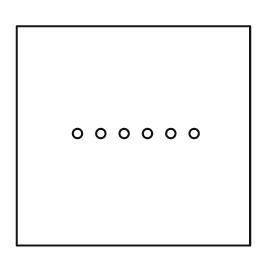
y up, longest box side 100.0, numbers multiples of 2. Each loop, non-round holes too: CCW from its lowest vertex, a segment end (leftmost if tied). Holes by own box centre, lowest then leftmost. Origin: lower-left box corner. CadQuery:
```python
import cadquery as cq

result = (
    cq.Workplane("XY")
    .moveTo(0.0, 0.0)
    .lineTo(100.0, 0.0)
    .lineTo(100.0, 94.0)
    .lineTo(0.0, 94.0)
    .close()
    .moveTo(26.0, 48.0)
    .circle(2.0)
    .moveTo(36.0, 48.0)
    .circle(2.0)
    .moveTo(46.0, 48.0)
    .circle(2.0)
    .moveTo(56.0, 48.0)
    .circle(2.0)
    .moveTo(66.0, 48.0)
    .circle(2.0)
    .moveTo(76.0, 48.0)
    .circle(2.0)
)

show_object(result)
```